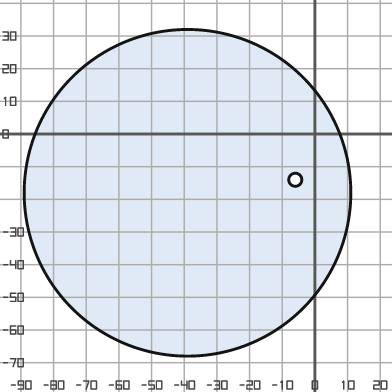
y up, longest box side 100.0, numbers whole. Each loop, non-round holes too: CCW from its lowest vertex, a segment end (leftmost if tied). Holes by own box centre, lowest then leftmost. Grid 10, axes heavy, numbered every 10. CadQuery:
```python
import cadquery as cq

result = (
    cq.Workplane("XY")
    .moveTo(-39.0, -18.0)
    .circle(50.0)
    .moveTo(-6.0, -14.0)
    .circle(2.0)
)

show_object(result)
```